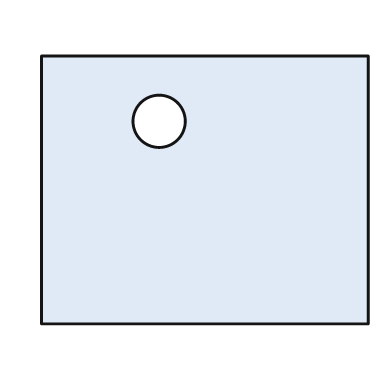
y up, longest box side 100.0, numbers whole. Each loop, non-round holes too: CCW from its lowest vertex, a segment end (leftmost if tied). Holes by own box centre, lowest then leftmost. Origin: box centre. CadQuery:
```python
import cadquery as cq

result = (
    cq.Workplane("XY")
    .moveTo(-50.0, -41.0)
    .lineTo(50.0, -41.0)
    .lineTo(50.0, 41.0)
    .lineTo(-50.0, 41.0)
    .close()
    .moveTo(-14.0, 21.0)
    .circle(8.0)
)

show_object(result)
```